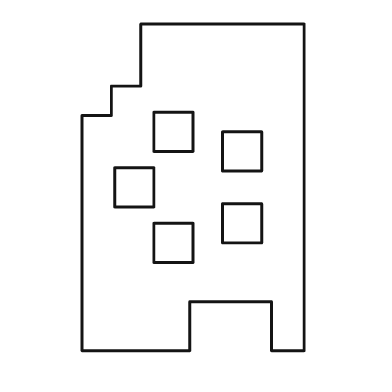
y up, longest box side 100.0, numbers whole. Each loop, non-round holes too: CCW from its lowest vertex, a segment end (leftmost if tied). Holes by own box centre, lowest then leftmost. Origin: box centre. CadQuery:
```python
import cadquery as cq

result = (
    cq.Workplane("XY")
    .moveTo(-34.0, -50.0)
    .lineTo(-1.0, -50.0)
    .lineTo(-1.0, -35.0)
    .lineTo(24.0, -35.0)
    .lineTo(24.0, -50.0)
    .lineTo(34.0, -50.0)
    .lineTo(34.0, 50.0)
    .lineTo(-16.0, 50.0)
    .lineTo(-16.0, 31.0)
    .lineTo(-25.0, 31.0)
    .lineTo(-25.0, 22.0)
    .lineTo(-34.0, 22.0)
    .close()
    .moveTo(-12.0, -23.0)
    .lineTo(0.0, -23.0)
    .lineTo(0.0, -11.0)
    .lineTo(-12.0, -11.0)
    .close()
    .moveTo(9.0, -17.0)
    .lineTo(21.0, -17.0)
    .lineTo(21.0, -5.0)
    .lineTo(9.0, -5.0)
    .close()
    .moveTo(-24.0, -6.0)
    .lineTo(-12.0, -6.0)
    .lineTo(-12.0, 6.0)
    .lineTo(-24.0, 6.0)
    .close()
    .moveTo(9.0, 5.0)
    .lineTo(21.0, 5.0)
    .lineTo(21.0, 17.0)
    .lineTo(9.0, 17.0)
    .close()
    .moveTo(-12.0, 11.0)
    .lineTo(0.0, 11.0)
    .lineTo(0.0, 23.0)
    .lineTo(-12.0, 23.0)
    .close()
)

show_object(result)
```